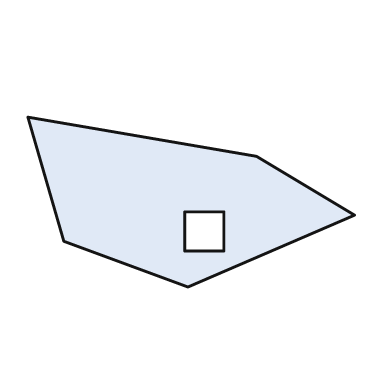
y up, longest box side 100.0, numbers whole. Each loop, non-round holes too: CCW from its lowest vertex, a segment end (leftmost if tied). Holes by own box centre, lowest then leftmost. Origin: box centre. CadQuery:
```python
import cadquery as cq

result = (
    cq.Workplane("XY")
    .moveTo(-1.0, -26.0)
    .lineTo(50.0, -4.0)
    .lineTo(20.0, 14.0)
    .lineTo(-50.0, 26.0)
    .lineTo(-39.0, -12.0)
    .close()
    .moveTo(-2.0, -15.0)
    .lineTo(10.0, -15.0)
    .lineTo(10.0, -3.0)
    .lineTo(-2.0, -3.0)
    .close()
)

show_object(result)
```